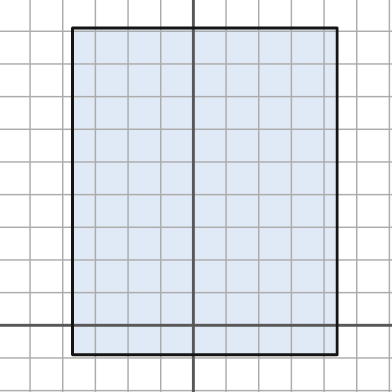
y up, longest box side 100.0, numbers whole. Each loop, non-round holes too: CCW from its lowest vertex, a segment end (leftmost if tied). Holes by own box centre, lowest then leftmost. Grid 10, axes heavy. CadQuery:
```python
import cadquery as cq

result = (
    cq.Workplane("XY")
    .moveTo(-37.0, -9.0)
    .lineTo(44.0, -9.0)
    .lineTo(44.0, 91.0)
    .lineTo(-37.0, 91.0)
    .close()
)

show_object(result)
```